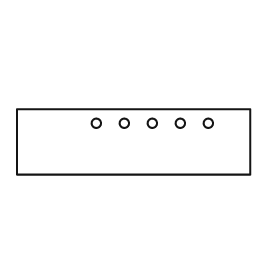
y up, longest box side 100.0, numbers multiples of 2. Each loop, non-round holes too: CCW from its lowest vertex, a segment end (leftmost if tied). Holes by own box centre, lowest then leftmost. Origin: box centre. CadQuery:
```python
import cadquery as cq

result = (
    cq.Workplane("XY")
    .moveTo(-50.0, -14.0)
    .lineTo(50.0, -14.0)
    .lineTo(50.0, 14.0)
    .lineTo(-50.0, 14.0)
    .close()
    .moveTo(-16.0, 8.0)
    .circle(2.0)
    .moveTo(-4.0, 8.0)
    .circle(2.0)
    .moveTo(8.0, 8.0)
    .circle(2.0)
    .moveTo(20.0, 8.0)
    .circle(2.0)
    .moveTo(32.0, 8.0)
    .circle(2.0)
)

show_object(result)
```